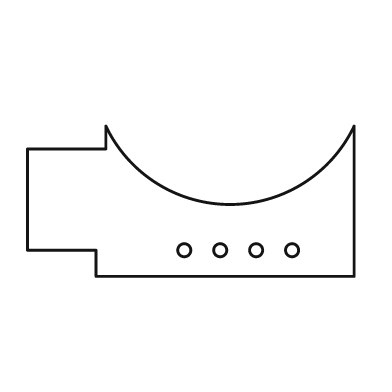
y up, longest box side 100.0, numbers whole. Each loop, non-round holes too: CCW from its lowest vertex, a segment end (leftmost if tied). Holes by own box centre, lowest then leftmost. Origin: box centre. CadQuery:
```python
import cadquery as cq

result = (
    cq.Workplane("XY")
    .moveTo(-29.0, -23.0)
    .lineTo(50.0, -23.0)
    .lineTo(50.0, 23.0)
    .threePointArc((12.0, -1.0), (-26.0, 23.0))
    .lineTo(-26.0, 16.0)
    .lineTo(-50.0, 16.0)
    .lineTo(-50.0, -15.0)
    .lineTo(-29.0, -15.0)
    .close()
    .moveTo(-2.0, -15.0)
    .circle(2.0)
    .moveTo(9.0, -15.0)
    .circle(2.0)
    .moveTo(20.0, -15.0)
    .circle(2.0)
    .moveTo(31.0, -15.0)
    .circle(2.0)
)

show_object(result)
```